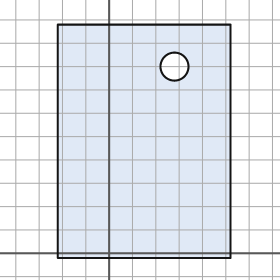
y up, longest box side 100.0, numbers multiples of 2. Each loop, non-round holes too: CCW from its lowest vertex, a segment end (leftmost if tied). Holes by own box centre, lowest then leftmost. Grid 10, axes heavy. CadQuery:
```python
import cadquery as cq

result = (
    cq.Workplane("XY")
    .moveTo(-22.0, -2.0)
    .lineTo(52.0, -2.0)
    .lineTo(52.0, 98.0)
    .lineTo(-22.0, 98.0)
    .close()
    .moveTo(28.0, 80.0)
    .circle(6.0)
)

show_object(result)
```